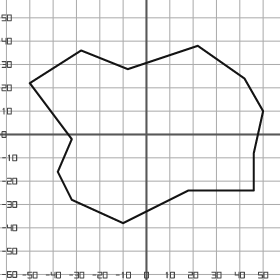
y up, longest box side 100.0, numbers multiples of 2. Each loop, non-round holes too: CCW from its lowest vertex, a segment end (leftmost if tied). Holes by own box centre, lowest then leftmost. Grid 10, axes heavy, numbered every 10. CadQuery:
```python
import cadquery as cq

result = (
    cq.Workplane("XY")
    .moveTo(-10.0, -38.0)
    .lineTo(18.0, -24.0)
    .lineTo(46.0, -24.0)
    .lineTo(46.0, -8.0)
    .lineTo(50.0, 10.0)
    .lineTo(42.0, 24.0)
    .lineTo(22.0, 38.0)
    .lineTo(-8.0, 28.0)
    .lineTo(-28.0, 36.0)
    .lineTo(-50.0, 22.0)
    .lineTo(-32.0, -2.0)
    .lineTo(-38.0, -16.0)
    .lineTo(-32.0, -28.0)
    .close()
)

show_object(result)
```